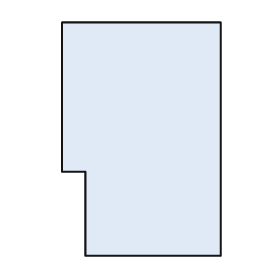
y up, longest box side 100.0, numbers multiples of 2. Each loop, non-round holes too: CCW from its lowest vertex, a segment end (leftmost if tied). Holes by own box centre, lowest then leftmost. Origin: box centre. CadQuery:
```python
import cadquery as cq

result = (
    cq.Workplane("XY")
    .moveTo(-24.0, -50.0)
    .lineTo(34.0, -50.0)
    .lineTo(34.0, 50.0)
    .lineTo(-34.0, 50.0)
    .lineTo(-34.0, -14.0)
    .lineTo(-24.0, -14.0)
    .close()
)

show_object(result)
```